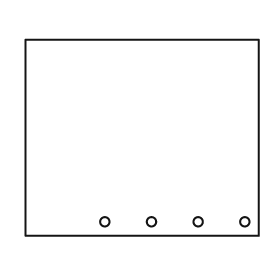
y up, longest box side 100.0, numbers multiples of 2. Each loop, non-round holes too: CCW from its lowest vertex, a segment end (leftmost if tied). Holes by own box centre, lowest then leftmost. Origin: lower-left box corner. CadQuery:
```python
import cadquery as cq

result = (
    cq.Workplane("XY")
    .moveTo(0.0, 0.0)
    .lineTo(100.0, 0.0)
    .lineTo(100.0, 84.0)
    .lineTo(0.0, 84.0)
    .close()
    .moveTo(34.0, 6.0)
    .circle(2.0)
    .moveTo(54.0, 6.0)
    .circle(2.0)
    .moveTo(74.0, 6.0)
    .circle(2.0)
    .moveTo(94.0, 6.0)
    .circle(2.0)
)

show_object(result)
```